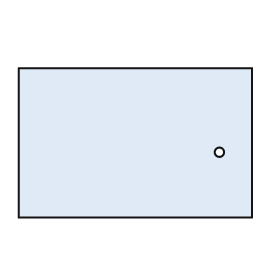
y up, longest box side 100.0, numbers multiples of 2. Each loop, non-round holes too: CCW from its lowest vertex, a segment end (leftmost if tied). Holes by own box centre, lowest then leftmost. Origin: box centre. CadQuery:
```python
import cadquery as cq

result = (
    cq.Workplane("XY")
    .moveTo(-50.0, -32.0)
    .lineTo(50.0, -32.0)
    .lineTo(50.0, 32.0)
    .lineTo(-50.0, 32.0)
    .close()
    .moveTo(36.0, -4.0)
    .circle(2.0)
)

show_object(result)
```